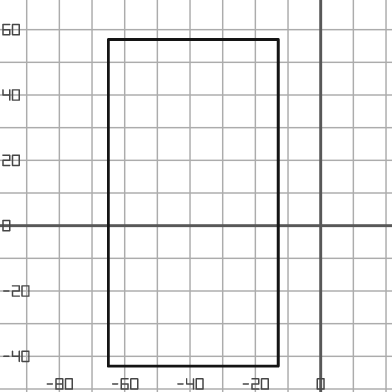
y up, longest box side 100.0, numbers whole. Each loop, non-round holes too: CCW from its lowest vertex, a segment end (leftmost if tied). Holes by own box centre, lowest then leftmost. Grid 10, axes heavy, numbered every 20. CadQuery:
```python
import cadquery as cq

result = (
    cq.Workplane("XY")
    .moveTo(-65.0, -43.0)
    .lineTo(-13.0, -43.0)
    .lineTo(-13.0, 57.0)
    .lineTo(-65.0, 57.0)
    .close()
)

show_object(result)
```